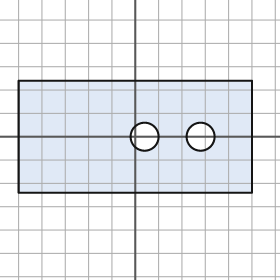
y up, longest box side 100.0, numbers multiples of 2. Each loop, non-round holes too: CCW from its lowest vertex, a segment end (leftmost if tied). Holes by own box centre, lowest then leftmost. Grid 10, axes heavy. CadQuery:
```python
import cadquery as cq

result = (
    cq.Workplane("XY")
    .moveTo(-50.0, -24.0)
    .lineTo(50.0, -24.0)
    .lineTo(50.0, 24.0)
    .lineTo(-50.0, 24.0)
    .close()
    .moveTo(4.0, 0.0)
    .circle(6.0)
    .moveTo(28.0, 0.0)
    .circle(6.0)
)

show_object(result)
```